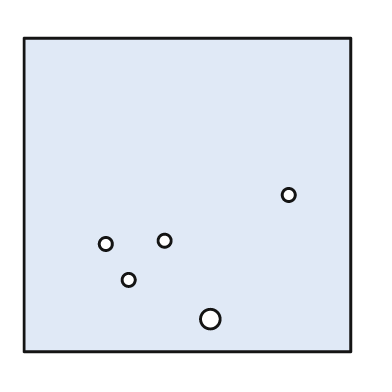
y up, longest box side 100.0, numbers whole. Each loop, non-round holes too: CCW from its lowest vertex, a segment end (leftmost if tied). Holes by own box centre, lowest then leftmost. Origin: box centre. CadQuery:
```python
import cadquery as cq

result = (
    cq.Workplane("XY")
    .moveTo(-50.0, -48.0)
    .lineTo(50.0, -48.0)
    .lineTo(50.0, 48.0)
    .lineTo(-50.0, 48.0)
    .close()
    .moveTo(7.0, -38.0)
    .circle(3.0)
    .moveTo(-18.0, -26.0)
    .circle(2.0)
    .moveTo(-25.0, -15.0)
    .circle(2.0)
    .moveTo(-7.0, -14.0)
    .circle(2.0)
    .moveTo(31.0, 0.0)
    .circle(2.0)
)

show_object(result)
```